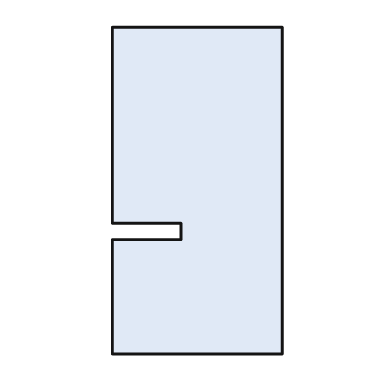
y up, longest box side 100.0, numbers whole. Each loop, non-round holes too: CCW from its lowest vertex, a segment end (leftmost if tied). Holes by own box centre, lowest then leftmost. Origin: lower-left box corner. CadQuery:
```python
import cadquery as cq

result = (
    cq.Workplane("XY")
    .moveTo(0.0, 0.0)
    .lineTo(52.0, 0.0)
    .lineTo(52.0, 100.0)
    .lineTo(0.0, 100.0)
    .lineTo(0.0, 40.0)
    .lineTo(21.0, 40.0)
    .lineTo(21.0, 35.0)
    .lineTo(0.0, 35.0)
    .close()
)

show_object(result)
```